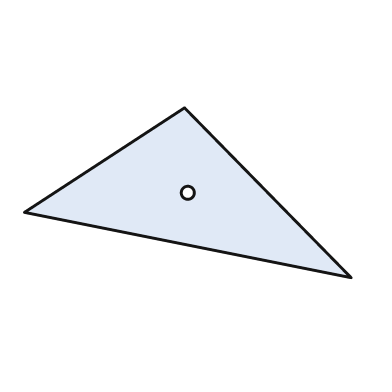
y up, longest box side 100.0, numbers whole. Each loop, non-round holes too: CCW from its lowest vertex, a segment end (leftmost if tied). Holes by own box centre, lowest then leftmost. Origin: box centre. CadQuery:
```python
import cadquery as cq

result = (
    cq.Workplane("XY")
    .moveTo(50.0, -26.0)
    .lineTo(-1.0, 26.0)
    .lineTo(-50.0, -6.0)
    .close()
    .moveTo(0.0, 0.0)
    .circle(2.0)
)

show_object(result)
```